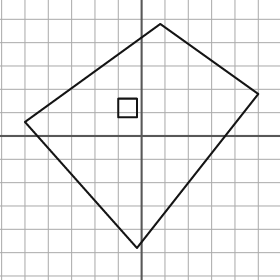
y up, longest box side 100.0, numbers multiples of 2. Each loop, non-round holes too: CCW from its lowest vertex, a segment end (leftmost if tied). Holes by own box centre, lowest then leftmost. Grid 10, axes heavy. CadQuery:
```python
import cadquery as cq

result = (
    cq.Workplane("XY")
    .moveTo(-2.0, -48.0)
    .lineTo(50.0, 18.0)
    .lineTo(8.0, 48.0)
    .lineTo(-50.0, 6.0)
    .close()
    .moveTo(-10.0, 8.0)
    .lineTo(-2.0, 8.0)
    .lineTo(-2.0, 16.0)
    .lineTo(-10.0, 16.0)
    .close()
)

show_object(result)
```